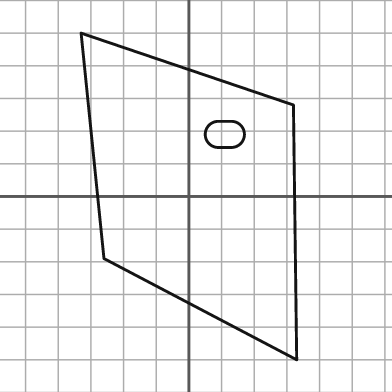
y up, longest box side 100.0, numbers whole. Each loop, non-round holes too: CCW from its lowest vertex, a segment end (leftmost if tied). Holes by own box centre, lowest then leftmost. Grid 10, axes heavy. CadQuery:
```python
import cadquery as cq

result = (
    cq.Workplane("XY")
    .moveTo(33.0, -50.0)
    .lineTo(32.0, 28.0)
    .lineTo(-33.0, 50.0)
    .lineTo(-26.0, -19.0)
    .close()
    .moveTo(9.0, 15.0)
    .lineTo(13.0, 15.0)
    .threePointArc((17.0, 19.0), (13.0, 23.0))
    .lineTo(9.0, 23.0)
    .threePointArc((5.0, 19.0), (9.0, 15.0))
    .close()
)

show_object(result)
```